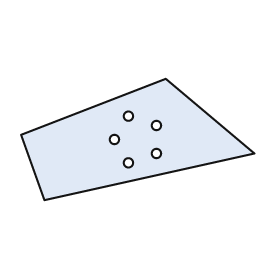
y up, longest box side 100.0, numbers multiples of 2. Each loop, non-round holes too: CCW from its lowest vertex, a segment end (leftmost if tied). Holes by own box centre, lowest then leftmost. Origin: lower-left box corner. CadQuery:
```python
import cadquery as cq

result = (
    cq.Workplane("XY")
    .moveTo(10.0, 0.0)
    .lineTo(100.0, 20.0)
    .lineTo(62.0, 52.0)
    .lineTo(0.0, 28.0)
    .close()
    .moveTo(46.0, 16.0)
    .circle(2.0)
    .moveTo(58.0, 20.0)
    .circle(2.0)
    .moveTo(40.0, 26.0)
    .circle(2.0)
    .moveTo(58.0, 32.0)
    .circle(2.0)
    .moveTo(46.0, 36.0)
    .circle(2.0)
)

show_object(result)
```